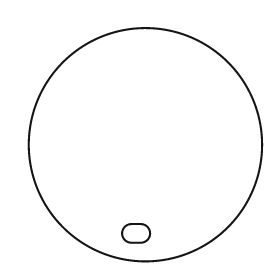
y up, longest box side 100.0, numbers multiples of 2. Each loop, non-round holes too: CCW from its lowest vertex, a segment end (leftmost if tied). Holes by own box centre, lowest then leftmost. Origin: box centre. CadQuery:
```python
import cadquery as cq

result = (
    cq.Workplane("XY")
    .moveTo(0.0, 0.0)
    .circle(50.0)
    .moveTo(-6.0, -42.0)
    .lineTo(-2.0, -42.0)
    .threePointArc((2.0, -38.0), (-2.0, -34.0))
    .lineTo(-6.0, -34.0)
    .threePointArc((-10.0, -38.0), (-6.0, -42.0))
    .close()
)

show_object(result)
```